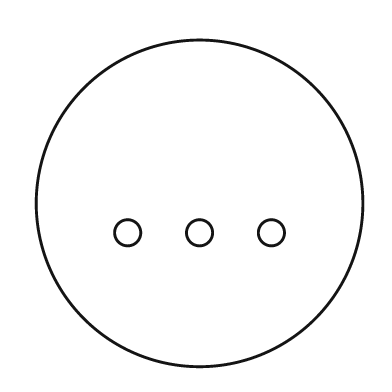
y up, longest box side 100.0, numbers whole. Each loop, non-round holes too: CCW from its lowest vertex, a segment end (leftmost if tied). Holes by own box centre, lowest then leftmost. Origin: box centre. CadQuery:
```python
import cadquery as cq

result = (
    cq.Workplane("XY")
    .moveTo(0.0, 0.0)
    .circle(50.0)
    .moveTo(-22.0, -9.0)
    .circle(4.0)
    .moveTo(0.0, -9.0)
    .circle(4.0)
    .moveTo(22.0, -9.0)
    .circle(4.0)
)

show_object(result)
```